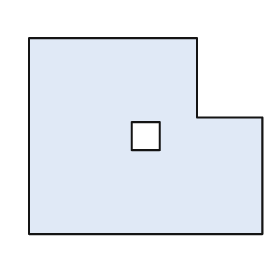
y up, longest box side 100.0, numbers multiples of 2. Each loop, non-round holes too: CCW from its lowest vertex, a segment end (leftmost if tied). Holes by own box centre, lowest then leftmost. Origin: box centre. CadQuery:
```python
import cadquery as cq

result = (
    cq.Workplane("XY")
    .moveTo(-50.0, -42.0)
    .lineTo(50.0, -42.0)
    .lineTo(50.0, 8.0)
    .lineTo(22.0, 8.0)
    .lineTo(22.0, 42.0)
    .lineTo(-50.0, 42.0)
    .close()
    .moveTo(-6.0, -6.0)
    .lineTo(6.0, -6.0)
    .lineTo(6.0, 6.0)
    .lineTo(-6.0, 6.0)
    .close()
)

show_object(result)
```